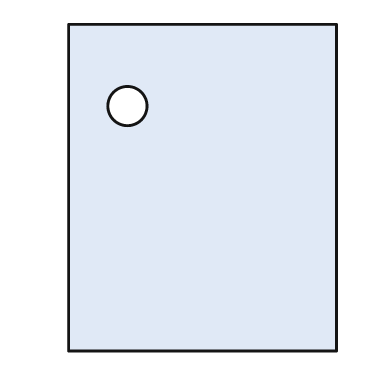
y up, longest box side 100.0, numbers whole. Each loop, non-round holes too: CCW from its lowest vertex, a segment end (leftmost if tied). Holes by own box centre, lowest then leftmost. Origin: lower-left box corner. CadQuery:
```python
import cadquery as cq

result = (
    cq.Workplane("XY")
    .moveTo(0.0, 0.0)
    .lineTo(82.0, 0.0)
    .lineTo(82.0, 100.0)
    .lineTo(0.0, 100.0)
    .close()
    .moveTo(18.0, 75.0)
    .circle(6.0)
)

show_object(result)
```